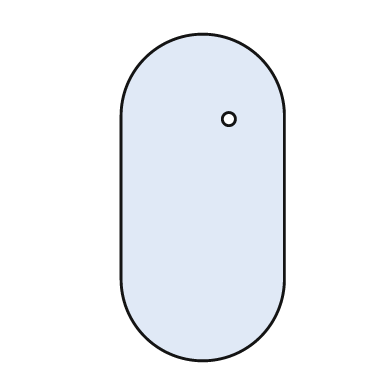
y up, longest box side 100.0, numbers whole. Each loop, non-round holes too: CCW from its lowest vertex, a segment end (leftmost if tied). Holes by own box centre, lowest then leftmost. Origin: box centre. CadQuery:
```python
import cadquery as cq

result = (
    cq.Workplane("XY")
    .moveTo(-25.0, -25.0)
    .threePointArc((0.0, -50.0), (25.0, -25.0))
    .lineTo(25.0, 25.0)
    .threePointArc((0.0, 50.0), (-25.0, 25.0))
    .close()
    .moveTo(8.0, 24.0)
    .circle(2.0)
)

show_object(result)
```